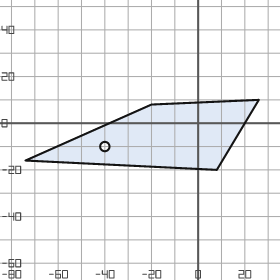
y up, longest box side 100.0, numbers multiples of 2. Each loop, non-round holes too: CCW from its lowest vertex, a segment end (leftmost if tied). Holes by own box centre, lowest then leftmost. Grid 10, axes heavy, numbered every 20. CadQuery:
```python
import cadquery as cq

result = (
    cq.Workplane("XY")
    .moveTo(8.0, -20.0)
    .lineTo(26.0, 10.0)
    .lineTo(-20.0, 8.0)
    .lineTo(-74.0, -16.0)
    .close()
    .moveTo(-40.0, -10.0)
    .circle(2.0)
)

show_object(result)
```